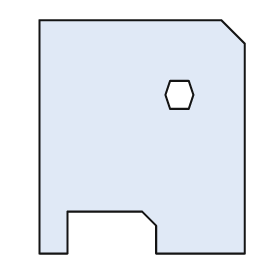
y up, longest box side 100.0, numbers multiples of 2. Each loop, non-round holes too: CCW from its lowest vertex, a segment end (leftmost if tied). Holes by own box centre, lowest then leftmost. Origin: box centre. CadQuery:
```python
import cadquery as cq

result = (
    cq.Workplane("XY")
    .moveTo(-44.0, -50.0)
    .lineTo(-32.0, -50.0)
    .lineTo(-32.0, -32.0)
    .lineTo(0.0, -32.0)
    .lineTo(6.0, -38.0)
    .lineTo(6.0, -50.0)
    .lineTo(44.0, -50.0)
    .lineTo(44.0, 40.0)
    .lineTo(34.0, 50.0)
    .lineTo(-44.0, 50.0)
    .close()
    .moveTo(12.0, 12.0)
    .lineTo(20.0, 12.0)
    .lineTo(22.0, 18.0)
    .lineTo(20.0, 24.0)
    .lineTo(12.0, 24.0)
    .lineTo(10.0, 18.0)
    .close()
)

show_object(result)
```